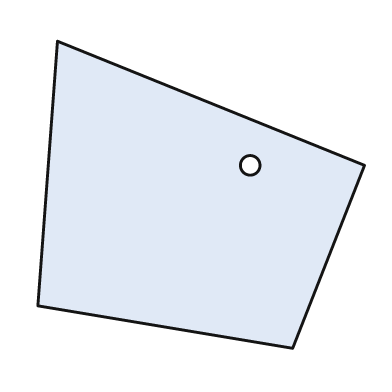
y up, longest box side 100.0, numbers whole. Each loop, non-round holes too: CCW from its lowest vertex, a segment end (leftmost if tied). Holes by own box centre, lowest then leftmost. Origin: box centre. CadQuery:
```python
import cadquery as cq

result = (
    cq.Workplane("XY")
    .moveTo(28.0, -47.0)
    .lineTo(50.0, 9.0)
    .lineTo(-44.0, 47.0)
    .lineTo(-50.0, -34.0)
    .close()
    .moveTo(15.0, 9.0)
    .circle(3.0)
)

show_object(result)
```